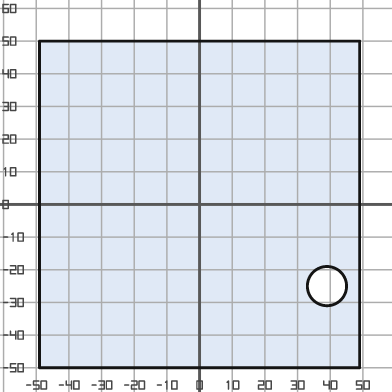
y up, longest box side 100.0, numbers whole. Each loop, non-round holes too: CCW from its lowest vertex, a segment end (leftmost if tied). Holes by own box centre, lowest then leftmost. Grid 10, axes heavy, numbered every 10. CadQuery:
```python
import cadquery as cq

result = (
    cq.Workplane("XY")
    .moveTo(-49.0, -50.0)
    .lineTo(49.0, -50.0)
    .lineTo(49.0, 50.0)
    .lineTo(-49.0, 50.0)
    .close()
    .moveTo(39.0, -25.0)
    .circle(6.0)
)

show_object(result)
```